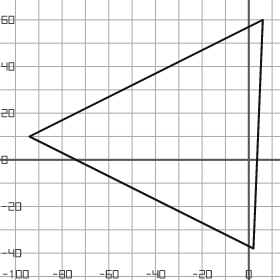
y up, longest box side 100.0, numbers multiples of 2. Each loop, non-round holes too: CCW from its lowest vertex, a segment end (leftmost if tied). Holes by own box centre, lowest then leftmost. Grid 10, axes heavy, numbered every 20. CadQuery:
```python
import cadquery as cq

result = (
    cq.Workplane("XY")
    .moveTo(2.0, -38.0)
    .lineTo(6.0, 60.0)
    .lineTo(-94.0, 10.0)
    .close()
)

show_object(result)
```